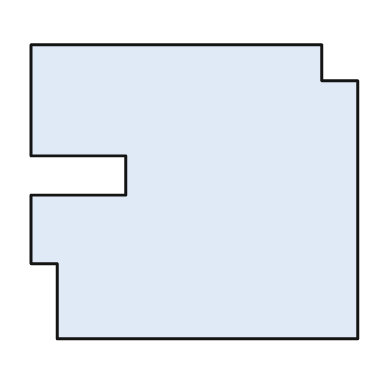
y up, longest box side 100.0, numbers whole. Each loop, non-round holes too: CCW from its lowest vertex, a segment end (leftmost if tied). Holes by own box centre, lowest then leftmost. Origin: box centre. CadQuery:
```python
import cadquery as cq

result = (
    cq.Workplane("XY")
    .moveTo(-42.0, -45.0)
    .lineTo(50.0, -45.0)
    .lineTo(50.0, 34.0)
    .lineTo(39.0, 34.0)
    .lineTo(39.0, 45.0)
    .lineTo(-50.0, 45.0)
    .lineTo(-50.0, 11.0)
    .lineTo(-21.0, 11.0)
    .lineTo(-21.0, -1.0)
    .lineTo(-50.0, -1.0)
    .lineTo(-50.0, -22.0)
    .lineTo(-42.0, -22.0)
    .close()
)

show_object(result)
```